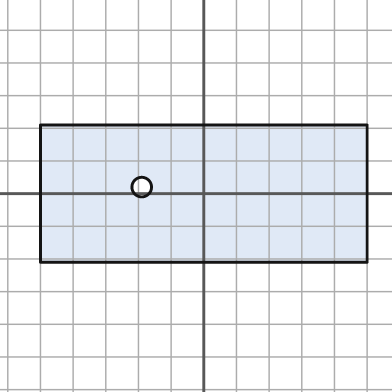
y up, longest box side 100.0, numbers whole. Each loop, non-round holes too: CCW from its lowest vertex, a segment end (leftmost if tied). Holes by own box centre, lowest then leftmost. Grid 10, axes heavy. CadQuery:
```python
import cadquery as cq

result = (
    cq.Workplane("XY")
    .moveTo(-50.0, -21.0)
    .lineTo(50.0, -21.0)
    .lineTo(50.0, 21.0)
    .lineTo(-50.0, 21.0)
    .close()
    .moveTo(-19.0, 2.0)
    .circle(3.0)
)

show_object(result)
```